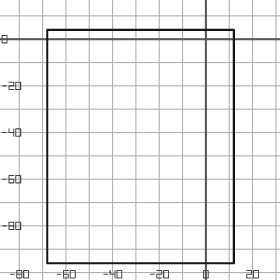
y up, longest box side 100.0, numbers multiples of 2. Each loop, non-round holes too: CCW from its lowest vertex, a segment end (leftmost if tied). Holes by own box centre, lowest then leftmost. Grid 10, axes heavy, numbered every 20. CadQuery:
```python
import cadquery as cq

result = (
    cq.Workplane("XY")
    .moveTo(-68.0, -96.0)
    .lineTo(12.0, -96.0)
    .lineTo(12.0, 4.0)
    .lineTo(-68.0, 4.0)
    .close()
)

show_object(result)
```